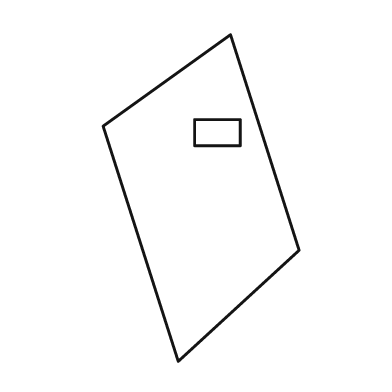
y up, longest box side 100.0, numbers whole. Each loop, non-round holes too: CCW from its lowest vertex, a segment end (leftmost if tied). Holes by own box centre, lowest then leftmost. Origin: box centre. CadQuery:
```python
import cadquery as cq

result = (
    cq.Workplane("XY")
    .moveTo(-7.0, -50.0)
    .lineTo(30.0, -16.0)
    .lineTo(9.0, 50.0)
    .lineTo(-30.0, 22.0)
    .close()
    .moveTo(-2.0, 16.0)
    .lineTo(12.0, 16.0)
    .lineTo(12.0, 24.0)
    .lineTo(-2.0, 24.0)
    .close()
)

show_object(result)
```